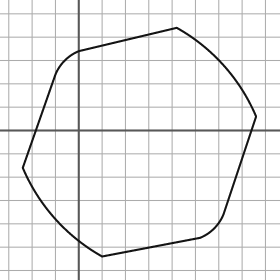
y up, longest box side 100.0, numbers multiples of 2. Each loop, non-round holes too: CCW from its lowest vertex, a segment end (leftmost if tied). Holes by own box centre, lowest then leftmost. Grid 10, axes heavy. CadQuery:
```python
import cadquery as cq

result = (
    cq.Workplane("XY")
    .moveTo(10.0, -54.0)
    .lineTo(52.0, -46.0)
    .threePointArc((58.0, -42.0), (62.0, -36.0))
    .lineTo(76.0, 6.0)
    .threePointArc((62.0, 28.0), (42.0, 44.0))
    .lineTo(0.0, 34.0)
    .threePointArc((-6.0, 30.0), (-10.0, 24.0))
    .lineTo(-24.0, -16.0)
    .threePointArc((-10.0, -38.0), (10.0, -54.0))
    .close()
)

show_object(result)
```